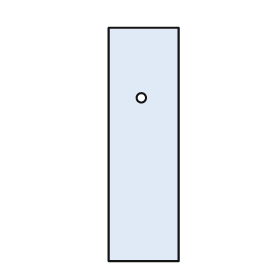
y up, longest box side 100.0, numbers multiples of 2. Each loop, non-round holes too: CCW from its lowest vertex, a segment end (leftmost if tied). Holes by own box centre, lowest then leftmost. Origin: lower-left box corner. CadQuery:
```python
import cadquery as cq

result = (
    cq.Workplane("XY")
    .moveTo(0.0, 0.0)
    .lineTo(30.0, 0.0)
    .lineTo(30.0, 100.0)
    .lineTo(0.0, 100.0)
    .close()
    .moveTo(14.0, 70.0)
    .circle(2.0)
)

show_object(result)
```